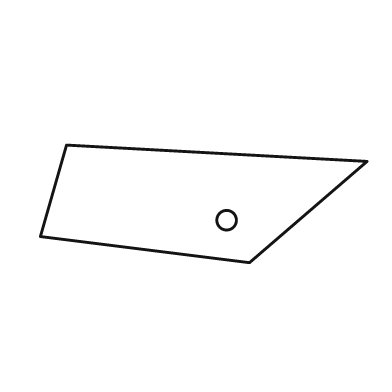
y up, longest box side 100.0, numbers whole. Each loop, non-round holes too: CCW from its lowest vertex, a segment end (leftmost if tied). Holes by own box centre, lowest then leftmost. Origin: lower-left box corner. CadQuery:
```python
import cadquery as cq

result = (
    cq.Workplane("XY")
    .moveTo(64.0, 0.0)
    .lineTo(100.0, 31.0)
    .lineTo(8.0, 36.0)
    .lineTo(0.0, 8.0)
    .close()
    .moveTo(57.0, 13.0)
    .circle(3.0)
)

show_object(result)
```